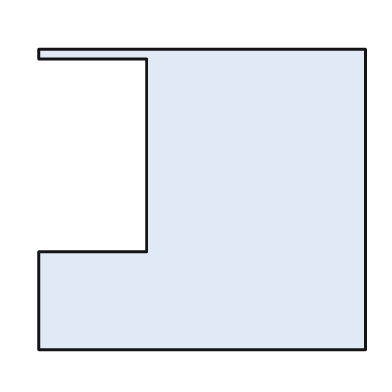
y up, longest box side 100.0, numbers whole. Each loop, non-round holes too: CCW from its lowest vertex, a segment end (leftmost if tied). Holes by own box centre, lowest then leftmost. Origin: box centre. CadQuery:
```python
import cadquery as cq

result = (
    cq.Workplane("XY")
    .moveTo(-50.0, -46.0)
    .lineTo(50.0, -46.0)
    .lineTo(50.0, 46.0)
    .lineTo(-50.0, 46.0)
    .lineTo(-50.0, 43.0)
    .lineTo(-17.0, 43.0)
    .lineTo(-17.0, -16.0)
    .lineTo(-50.0, -16.0)
    .close()
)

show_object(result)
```